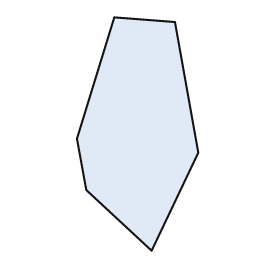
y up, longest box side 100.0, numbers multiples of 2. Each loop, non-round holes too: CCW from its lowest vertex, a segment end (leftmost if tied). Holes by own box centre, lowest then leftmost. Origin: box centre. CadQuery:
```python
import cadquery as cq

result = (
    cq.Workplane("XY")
    .moveTo(6.0, -50.0)
    .lineTo(26.0, -8.0)
    .lineTo(16.0, 48.0)
    .lineTo(-10.0, 50.0)
    .lineTo(-26.0, -2.0)
    .lineTo(-22.0, -24.0)
    .close()
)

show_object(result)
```